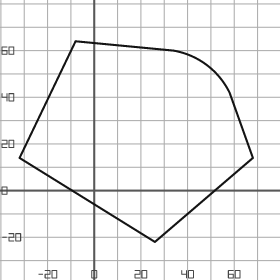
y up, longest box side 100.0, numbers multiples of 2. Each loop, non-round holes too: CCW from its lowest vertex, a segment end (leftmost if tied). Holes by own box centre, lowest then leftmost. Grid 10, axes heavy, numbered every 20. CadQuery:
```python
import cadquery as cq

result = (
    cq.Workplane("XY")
    .moveTo(26.0, -22.0)
    .lineTo(68.0, 14.0)
    .lineTo(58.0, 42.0)
    .threePointArc((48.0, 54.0), (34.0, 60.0))
    .lineTo(-8.0, 64.0)
    .lineTo(-32.0, 14.0)
    .close()
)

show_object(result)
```